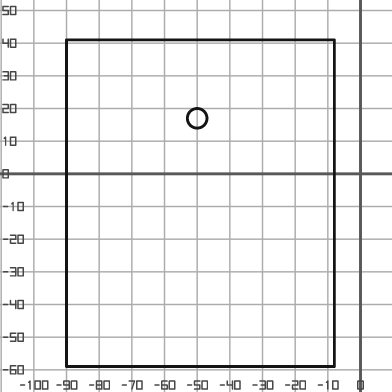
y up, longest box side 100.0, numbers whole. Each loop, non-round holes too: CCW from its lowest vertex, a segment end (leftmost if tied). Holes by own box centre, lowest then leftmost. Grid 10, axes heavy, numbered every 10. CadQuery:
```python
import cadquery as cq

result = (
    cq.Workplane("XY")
    .moveTo(-90.0, -59.0)
    .lineTo(-8.0, -59.0)
    .lineTo(-8.0, 41.0)
    .lineTo(-90.0, 41.0)
    .close()
    .moveTo(-50.0, 17.0)
    .circle(3.0)
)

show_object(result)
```